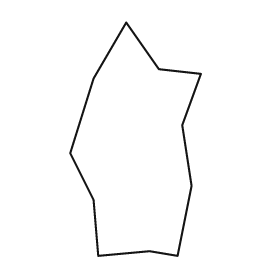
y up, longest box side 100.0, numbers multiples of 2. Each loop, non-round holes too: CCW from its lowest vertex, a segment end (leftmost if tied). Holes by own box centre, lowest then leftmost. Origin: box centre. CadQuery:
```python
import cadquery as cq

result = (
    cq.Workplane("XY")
    .moveTo(-16.0, -50.0)
    .lineTo(6.0, -48.0)
    .lineTo(18.0, -50.0)
    .lineTo(24.0, -20.0)
    .lineTo(20.0, 6.0)
    .lineTo(28.0, 28.0)
    .lineTo(10.0, 30.0)
    .lineTo(-4.0, 50.0)
    .lineTo(-18.0, 26.0)
    .lineTo(-28.0, -6.0)
    .lineTo(-18.0, -26.0)
    .close()
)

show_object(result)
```